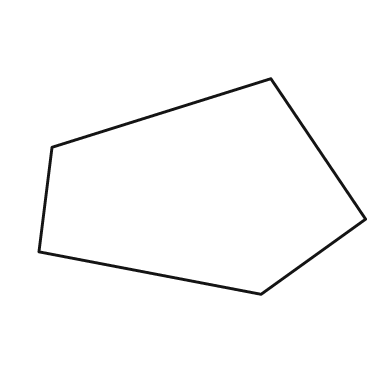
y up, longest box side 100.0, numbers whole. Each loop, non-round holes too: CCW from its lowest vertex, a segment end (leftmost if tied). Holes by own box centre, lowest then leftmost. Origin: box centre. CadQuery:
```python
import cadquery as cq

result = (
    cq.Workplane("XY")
    .moveTo(18.0, -33.0)
    .lineTo(50.0, -10.0)
    .lineTo(21.0, 33.0)
    .lineTo(-46.0, 12.0)
    .lineTo(-50.0, -20.0)
    .close()
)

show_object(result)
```